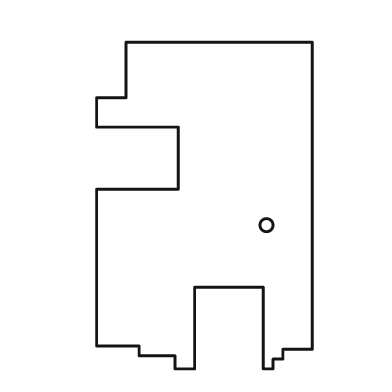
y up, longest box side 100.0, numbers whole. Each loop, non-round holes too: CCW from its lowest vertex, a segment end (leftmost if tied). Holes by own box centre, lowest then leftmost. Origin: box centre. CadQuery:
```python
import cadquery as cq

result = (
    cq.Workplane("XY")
    .moveTo(-9.0, -50.0)
    .lineTo(-3.0, -50.0)
    .lineTo(-3.0, -25.0)
    .lineTo(18.0, -25.0)
    .lineTo(18.0, -50.0)
    .lineTo(21.0, -50.0)
    .lineTo(21.0, -47.0)
    .lineTo(24.0, -47.0)
    .lineTo(24.0, -44.0)
    .lineTo(33.0, -44.0)
    .lineTo(33.0, 50.0)
    .lineTo(-24.0, 50.0)
    .lineTo(-24.0, 33.0)
    .lineTo(-33.0, 33.0)
    .lineTo(-33.0, 24.0)
    .lineTo(-8.0, 24.0)
    .lineTo(-8.0, 5.0)
    .lineTo(-33.0, 5.0)
    .lineTo(-33.0, -43.0)
    .lineTo(-20.0, -43.0)
    .lineTo(-20.0, -46.0)
    .lineTo(-9.0, -46.0)
    .close()
    .moveTo(19.0, -6.0)
    .circle(2.0)
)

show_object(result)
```